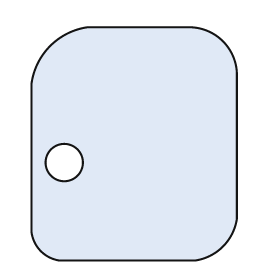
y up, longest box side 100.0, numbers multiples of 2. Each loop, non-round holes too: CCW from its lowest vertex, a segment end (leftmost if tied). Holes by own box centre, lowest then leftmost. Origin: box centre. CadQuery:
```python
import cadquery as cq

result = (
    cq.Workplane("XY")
    .moveTo(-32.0, -50.0)
    .lineTo(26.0, -50.0)
    .threePointArc((38.0, -44.0), (44.0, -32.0))
    .lineTo(44.0, 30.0)
    .threePointArc((38.0, 44.0), (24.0, 50.0))
    .lineTo(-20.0, 50.0)
    .threePointArc((-36.0, 42.0), (-44.0, 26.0))
    .lineTo(-44.0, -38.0)
    .threePointArc((-40.0, -46.0), (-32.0, -50.0))
    .close()
    .moveTo(-30.0, -8.0)
    .circle(8.0)
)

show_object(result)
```